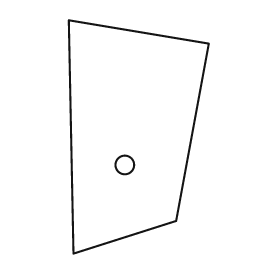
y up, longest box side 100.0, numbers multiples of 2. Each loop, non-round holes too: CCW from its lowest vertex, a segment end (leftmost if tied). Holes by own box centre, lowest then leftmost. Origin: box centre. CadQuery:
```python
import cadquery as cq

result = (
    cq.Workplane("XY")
    .moveTo(-28.0, -50.0)
    .lineTo(16.0, -36.0)
    .lineTo(30.0, 40.0)
    .lineTo(-30.0, 50.0)
    .close()
    .moveTo(-6.0, -12.0)
    .circle(4.0)
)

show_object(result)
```